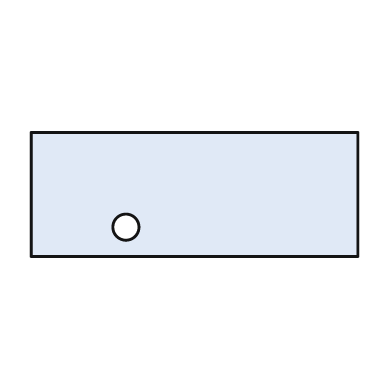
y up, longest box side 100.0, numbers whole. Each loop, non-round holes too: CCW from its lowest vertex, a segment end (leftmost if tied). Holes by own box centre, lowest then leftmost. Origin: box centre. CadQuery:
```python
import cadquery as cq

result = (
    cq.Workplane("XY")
    .moveTo(-50.0, -19.0)
    .lineTo(50.0, -19.0)
    .lineTo(50.0, 19.0)
    .lineTo(-50.0, 19.0)
    .close()
    .moveTo(-21.0, -10.0)
    .circle(4.0)
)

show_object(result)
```